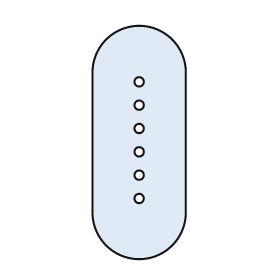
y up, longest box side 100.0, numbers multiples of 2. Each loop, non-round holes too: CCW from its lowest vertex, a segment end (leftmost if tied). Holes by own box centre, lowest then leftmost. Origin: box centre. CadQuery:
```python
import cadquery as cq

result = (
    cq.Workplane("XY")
    .moveTo(-20.0, -30.0)
    .threePointArc((0.0, -50.0), (20.0, -30.0))
    .lineTo(20.0, 30.0)
    .threePointArc((0.0, 50.0), (-20.0, 30.0))
    .close()
    .moveTo(0.0, -24.0)
    .circle(2.0)
    .moveTo(0.0, -14.0)
    .circle(2.0)
    .moveTo(0.0, -4.0)
    .circle(2.0)
    .moveTo(0.0, 6.0)
    .circle(2.0)
    .moveTo(0.0, 16.0)
    .circle(2.0)
    .moveTo(0.0, 26.0)
    .circle(2.0)
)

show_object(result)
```